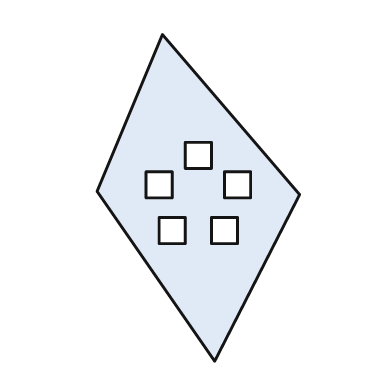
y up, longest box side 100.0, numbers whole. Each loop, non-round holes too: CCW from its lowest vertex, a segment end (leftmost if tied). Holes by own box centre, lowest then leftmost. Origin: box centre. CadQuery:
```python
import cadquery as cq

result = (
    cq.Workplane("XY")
    .moveTo(5.0, -50.0)
    .lineTo(31.0, 1.0)
    .lineTo(-11.0, 50.0)
    .lineTo(-31.0, 2.0)
    .close()
    .moveTo(-12.0, -14.0)
    .lineTo(-4.0, -14.0)
    .lineTo(-4.0, -6.0)
    .lineTo(-12.0, -6.0)
    .close()
    .moveTo(4.0, -14.0)
    .lineTo(12.0, -14.0)
    .lineTo(12.0, -6.0)
    .lineTo(4.0, -6.0)
    .close()
    .moveTo(-16.0, 0.0)
    .lineTo(-8.0, 0.0)
    .lineTo(-8.0, 8.0)
    .lineTo(-16.0, 8.0)
    .close()
    .moveTo(8.0, 0.0)
    .lineTo(16.0, 0.0)
    .lineTo(16.0, 8.0)
    .lineTo(8.0, 8.0)
    .close()
    .moveTo(-4.0, 9.0)
    .lineTo(4.0, 9.0)
    .lineTo(4.0, 17.0)
    .lineTo(-4.0, 17.0)
    .close()
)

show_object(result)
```